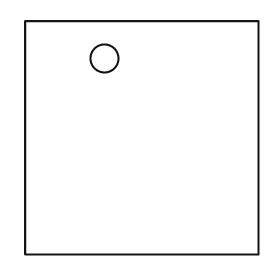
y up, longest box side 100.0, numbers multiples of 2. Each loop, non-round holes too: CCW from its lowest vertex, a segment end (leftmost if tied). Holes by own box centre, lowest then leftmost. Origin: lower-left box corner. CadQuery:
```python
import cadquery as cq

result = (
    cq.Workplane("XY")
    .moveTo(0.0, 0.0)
    .lineTo(100.0, 0.0)
    .lineTo(100.0, 100.0)
    .lineTo(0.0, 100.0)
    .close()
    .moveTo(34.0, 84.0)
    .circle(6.0)
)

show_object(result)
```